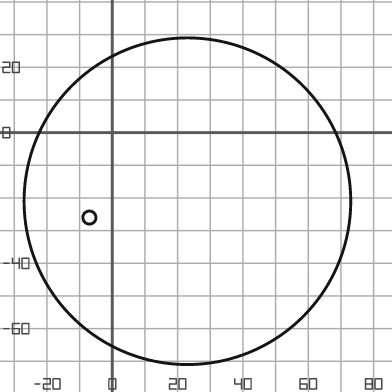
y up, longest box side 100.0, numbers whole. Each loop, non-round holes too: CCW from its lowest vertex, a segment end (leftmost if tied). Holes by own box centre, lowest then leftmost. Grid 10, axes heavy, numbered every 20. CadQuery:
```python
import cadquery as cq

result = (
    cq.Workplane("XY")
    .moveTo(23.0, -21.0)
    .circle(50.0)
    .moveTo(-7.0, -26.0)
    .circle(2.0)
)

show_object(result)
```